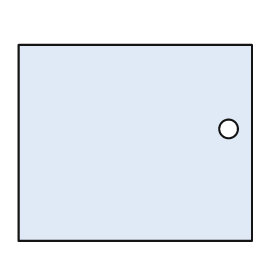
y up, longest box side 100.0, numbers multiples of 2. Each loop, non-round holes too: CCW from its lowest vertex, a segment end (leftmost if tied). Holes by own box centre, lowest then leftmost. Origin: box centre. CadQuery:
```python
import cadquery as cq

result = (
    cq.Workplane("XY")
    .moveTo(-50.0, -42.0)
    .lineTo(50.0, -42.0)
    .lineTo(50.0, 42.0)
    .lineTo(-50.0, 42.0)
    .close()
    .moveTo(40.0, 6.0)
    .circle(4.0)
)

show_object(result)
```